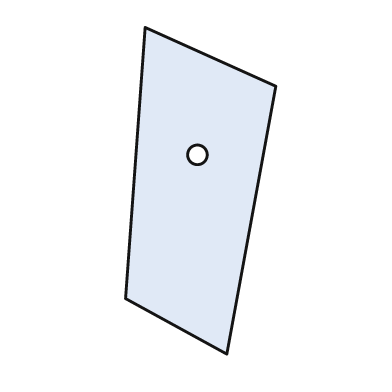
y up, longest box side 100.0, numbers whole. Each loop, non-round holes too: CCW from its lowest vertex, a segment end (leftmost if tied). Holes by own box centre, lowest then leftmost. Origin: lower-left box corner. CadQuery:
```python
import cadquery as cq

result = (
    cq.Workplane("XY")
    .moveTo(31.0, 0.0)
    .lineTo(46.0, 82.0)
    .lineTo(6.0, 100.0)
    .lineTo(0.0, 17.0)
    .close()
    .moveTo(22.0, 61.0)
    .circle(3.0)
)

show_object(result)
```